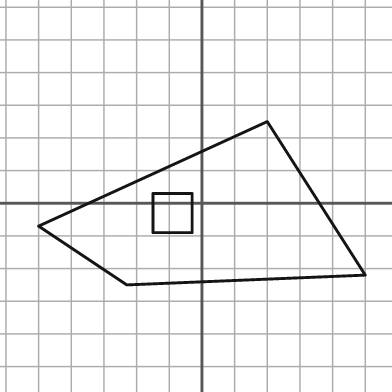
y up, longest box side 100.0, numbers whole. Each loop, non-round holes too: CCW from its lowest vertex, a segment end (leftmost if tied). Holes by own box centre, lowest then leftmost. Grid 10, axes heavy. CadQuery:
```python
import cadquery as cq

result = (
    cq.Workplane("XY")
    .moveTo(-23.0, -25.0)
    .lineTo(50.0, -22.0)
    .lineTo(20.0, 25.0)
    .lineTo(-50.0, -7.0)
    .close()
    .moveTo(-15.0, -9.0)
    .lineTo(-3.0, -9.0)
    .lineTo(-3.0, 3.0)
    .lineTo(-15.0, 3.0)
    .close()
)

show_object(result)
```